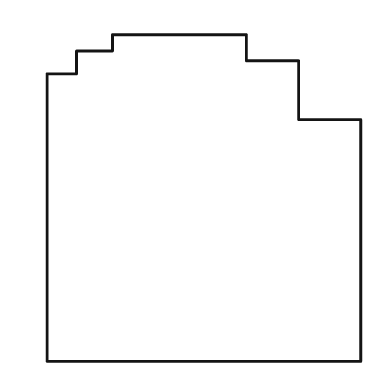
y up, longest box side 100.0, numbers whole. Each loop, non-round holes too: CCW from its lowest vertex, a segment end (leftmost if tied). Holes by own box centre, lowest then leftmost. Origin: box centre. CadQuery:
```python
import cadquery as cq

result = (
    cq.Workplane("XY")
    .moveTo(-48.0, -50.0)
    .lineTo(48.0, -50.0)
    .lineTo(48.0, 24.0)
    .lineTo(29.0, 24.0)
    .lineTo(29.0, 42.0)
    .lineTo(13.0, 42.0)
    .lineTo(13.0, 50.0)
    .lineTo(-28.0, 50.0)
    .lineTo(-28.0, 45.0)
    .lineTo(-39.0, 45.0)
    .lineTo(-39.0, 38.0)
    .lineTo(-48.0, 38.0)
    .close()
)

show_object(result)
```